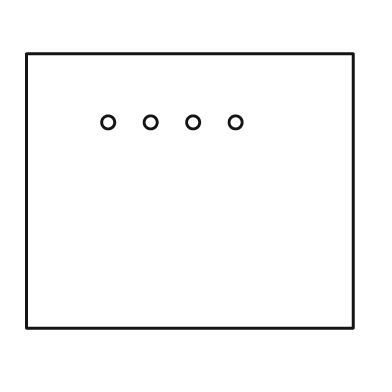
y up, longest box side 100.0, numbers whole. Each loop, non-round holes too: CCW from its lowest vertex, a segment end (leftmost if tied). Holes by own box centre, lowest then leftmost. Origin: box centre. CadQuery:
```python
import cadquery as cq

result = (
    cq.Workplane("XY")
    .moveTo(-50.0, -42.0)
    .lineTo(50.0, -42.0)
    .lineTo(50.0, 42.0)
    .lineTo(-50.0, 42.0)
    .close()
    .moveTo(-25.0, 21.0)
    .circle(2.0)
    .moveTo(-12.0, 21.0)
    .circle(2.0)
    .moveTo(1.0, 21.0)
    .circle(2.0)
    .moveTo(14.0, 21.0)
    .circle(2.0)
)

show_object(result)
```